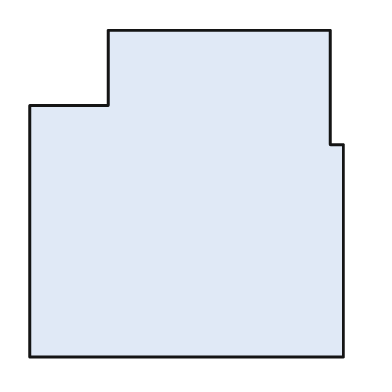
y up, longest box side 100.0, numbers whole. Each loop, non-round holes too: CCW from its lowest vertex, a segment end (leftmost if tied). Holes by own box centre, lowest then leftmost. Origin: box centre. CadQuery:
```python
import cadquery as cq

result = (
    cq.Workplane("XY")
    .moveTo(-48.0, -50.0)
    .lineTo(48.0, -50.0)
    .lineTo(48.0, 15.0)
    .lineTo(44.0, 15.0)
    .lineTo(44.0, 50.0)
    .lineTo(-24.0, 50.0)
    .lineTo(-24.0, 27.0)
    .lineTo(-48.0, 27.0)
    .close()
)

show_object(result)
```